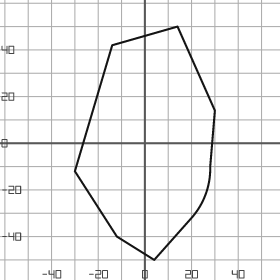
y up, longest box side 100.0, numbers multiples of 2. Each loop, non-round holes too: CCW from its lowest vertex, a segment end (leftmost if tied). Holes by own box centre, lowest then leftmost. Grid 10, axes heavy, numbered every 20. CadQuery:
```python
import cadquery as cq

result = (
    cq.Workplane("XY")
    .moveTo(4.0, -50.0)
    .lineTo(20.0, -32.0)
    .threePointArc((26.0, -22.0), (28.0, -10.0))
    .lineTo(30.0, 14.0)
    .lineTo(14.0, 50.0)
    .lineTo(-14.0, 42.0)
    .lineTo(-30.0, -12.0)
    .lineTo(-12.0, -40.0)
    .close()
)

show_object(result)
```